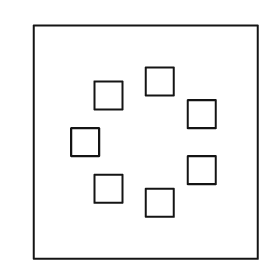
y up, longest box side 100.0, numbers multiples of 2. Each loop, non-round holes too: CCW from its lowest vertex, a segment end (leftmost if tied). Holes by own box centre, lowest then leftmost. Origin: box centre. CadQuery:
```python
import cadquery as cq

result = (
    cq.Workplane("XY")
    .moveTo(-48.0, -50.0)
    .lineTo(48.0, -50.0)
    .lineTo(48.0, 50.0)
    .lineTo(-48.0, 50.0)
    .close()
    .moveTo(0.0, -32.0)
    .lineTo(12.0, -32.0)
    .lineTo(12.0, -20.0)
    .lineTo(0.0, -20.0)
    .close()
    .moveTo(-22.0, -26.0)
    .lineTo(-10.0, -26.0)
    .lineTo(-10.0, -14.0)
    .lineTo(-22.0, -14.0)
    .close()
    .moveTo(18.0, -18.0)
    .lineTo(30.0, -18.0)
    .lineTo(30.0, -6.0)
    .lineTo(18.0, -6.0)
    .close()
    .moveTo(-32.0, -6.0)
    .lineTo(-20.0, -6.0)
    .lineTo(-20.0, 6.0)
    .lineTo(-32.0, 6.0)
    .close()
    .moveTo(18.0, 6.0)
    .lineTo(30.0, 6.0)
    .lineTo(30.0, 18.0)
    .lineTo(18.0, 18.0)
    .close()
    .moveTo(-22.0, 14.0)
    .lineTo(-10.0, 14.0)
    .lineTo(-10.0, 26.0)
    .lineTo(-22.0, 26.0)
    .close()
    .moveTo(0.0, 20.0)
    .lineTo(12.0, 20.0)
    .lineTo(12.0, 32.0)
    .lineTo(0.0, 32.0)
    .close()
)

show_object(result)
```